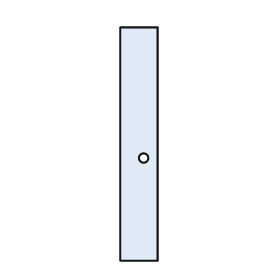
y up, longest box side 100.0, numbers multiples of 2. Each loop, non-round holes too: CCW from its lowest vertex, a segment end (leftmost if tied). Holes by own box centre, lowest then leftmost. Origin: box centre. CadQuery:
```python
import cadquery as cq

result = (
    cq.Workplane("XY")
    .moveTo(-8.0, -50.0)
    .lineTo(8.0, -50.0)
    .lineTo(8.0, 50.0)
    .lineTo(-8.0, 50.0)
    .close()
    .moveTo(2.0, -6.0)
    .circle(2.0)
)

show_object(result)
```